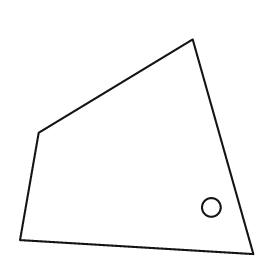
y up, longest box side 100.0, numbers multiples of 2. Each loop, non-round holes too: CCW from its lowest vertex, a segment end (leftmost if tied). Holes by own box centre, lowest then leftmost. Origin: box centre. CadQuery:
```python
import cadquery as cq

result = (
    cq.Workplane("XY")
    .moveTo(50.0, -46.0)
    .lineTo(24.0, 46.0)
    .lineTo(-42.0, 6.0)
    .lineTo(-50.0, -40.0)
    .close()
    .moveTo(32.0, -26.0)
    .circle(4.0)
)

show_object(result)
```